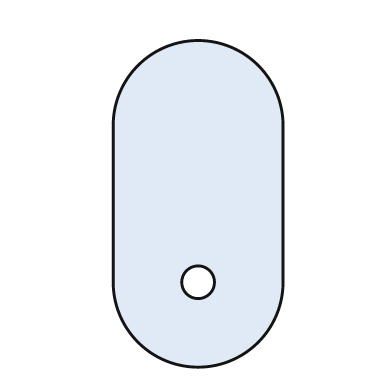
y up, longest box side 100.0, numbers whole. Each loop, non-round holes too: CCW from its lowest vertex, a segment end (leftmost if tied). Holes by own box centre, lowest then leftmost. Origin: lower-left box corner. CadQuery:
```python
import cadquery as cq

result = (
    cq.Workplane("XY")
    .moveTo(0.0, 26.0)
    .threePointArc((26.0, 0.0), (52.0, 26.0))
    .lineTo(52.0, 74.0)
    .threePointArc((26.0, 100.0), (0.0, 74.0))
    .close()
    .moveTo(26.0, 26.0)
    .circle(5.0)
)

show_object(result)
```